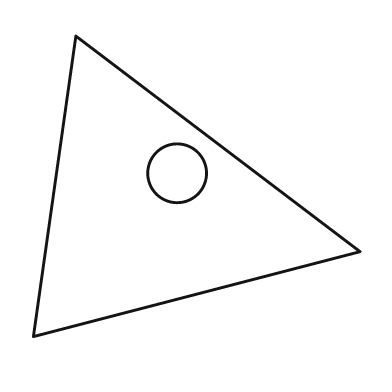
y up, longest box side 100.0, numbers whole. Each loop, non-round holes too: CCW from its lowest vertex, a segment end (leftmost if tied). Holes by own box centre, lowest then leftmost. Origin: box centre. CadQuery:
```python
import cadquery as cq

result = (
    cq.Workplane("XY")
    .moveTo(-50.0, -46.0)
    .lineTo(50.0, -20.0)
    .lineTo(-37.0, 46.0)
    .close()
    .moveTo(-6.0, 4.0)
    .circle(9.0)
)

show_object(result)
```